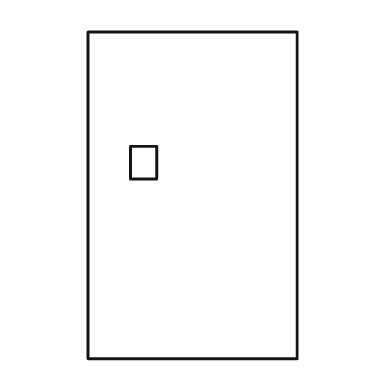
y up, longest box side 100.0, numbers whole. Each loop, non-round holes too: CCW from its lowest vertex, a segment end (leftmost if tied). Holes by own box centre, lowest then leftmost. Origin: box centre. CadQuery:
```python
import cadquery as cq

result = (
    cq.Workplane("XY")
    .moveTo(-32.0, -50.0)
    .lineTo(32.0, -50.0)
    .lineTo(32.0, 50.0)
    .lineTo(-32.0, 50.0)
    .close()
    .moveTo(-19.0, 5.0)
    .lineTo(-11.0, 5.0)
    .lineTo(-11.0, 15.0)
    .lineTo(-19.0, 15.0)
    .close()
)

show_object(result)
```